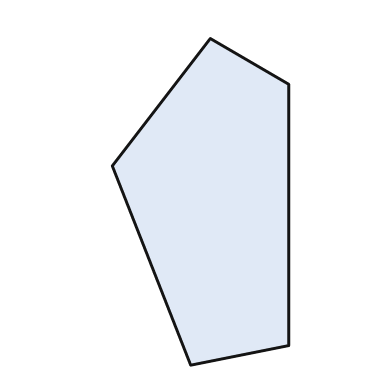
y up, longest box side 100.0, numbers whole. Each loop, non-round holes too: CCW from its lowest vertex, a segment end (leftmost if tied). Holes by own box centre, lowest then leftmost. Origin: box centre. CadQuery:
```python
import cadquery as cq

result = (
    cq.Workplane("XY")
    .moveTo(-3.0, -50.0)
    .lineTo(27.0, -44.0)
    .lineTo(27.0, 36.0)
    .lineTo(3.0, 50.0)
    .lineTo(-27.0, 11.0)
    .close()
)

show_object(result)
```